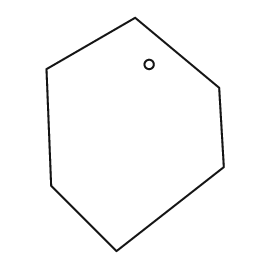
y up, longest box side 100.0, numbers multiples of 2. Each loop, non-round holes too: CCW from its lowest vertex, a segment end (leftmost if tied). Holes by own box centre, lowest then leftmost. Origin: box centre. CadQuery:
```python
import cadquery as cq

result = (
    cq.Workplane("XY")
    .moveTo(-8.0, -50.0)
    .lineTo(38.0, -14.0)
    .lineTo(36.0, 20.0)
    .lineTo(0.0, 50.0)
    .lineTo(-38.0, 28.0)
    .lineTo(-36.0, -22.0)
    .close()
    .moveTo(6.0, 30.0)
    .circle(2.0)
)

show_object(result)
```